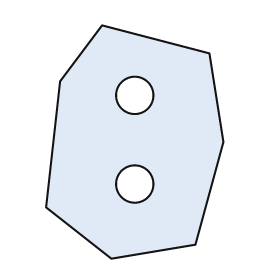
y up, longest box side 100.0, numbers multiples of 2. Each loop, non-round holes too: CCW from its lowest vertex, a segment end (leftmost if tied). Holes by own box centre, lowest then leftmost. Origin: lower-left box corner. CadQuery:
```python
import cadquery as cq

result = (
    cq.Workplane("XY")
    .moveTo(28.0, 0.0)
    .lineTo(64.0, 6.0)
    .lineTo(76.0, 50.0)
    .lineTo(70.0, 88.0)
    .lineTo(24.0, 100.0)
    .lineTo(6.0, 76.0)
    .lineTo(0.0, 22.0)
    .close()
    .moveTo(38.0, 32.0)
    .circle(8.0)
    .moveTo(38.0, 70.0)
    .circle(8.0)
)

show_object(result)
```